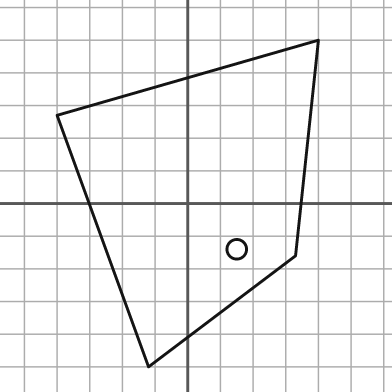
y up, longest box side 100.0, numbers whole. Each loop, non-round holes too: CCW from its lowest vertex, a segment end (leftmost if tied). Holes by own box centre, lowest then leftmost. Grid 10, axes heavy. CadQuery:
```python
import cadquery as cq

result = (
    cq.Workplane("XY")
    .moveTo(-12.0, -50.0)
    .lineTo(33.0, -16.0)
    .lineTo(40.0, 50.0)
    .lineTo(-40.0, 27.0)
    .close()
    .moveTo(15.0, -14.0)
    .circle(3.0)
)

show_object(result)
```